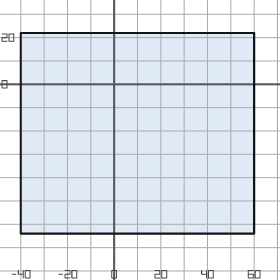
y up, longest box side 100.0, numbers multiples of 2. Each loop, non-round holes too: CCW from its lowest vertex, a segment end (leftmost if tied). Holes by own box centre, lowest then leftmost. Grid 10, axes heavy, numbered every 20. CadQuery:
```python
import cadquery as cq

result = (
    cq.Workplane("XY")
    .moveTo(-40.0, -64.0)
    .lineTo(60.0, -64.0)
    .lineTo(60.0, 22.0)
    .lineTo(-40.0, 22.0)
    .close()
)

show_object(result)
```